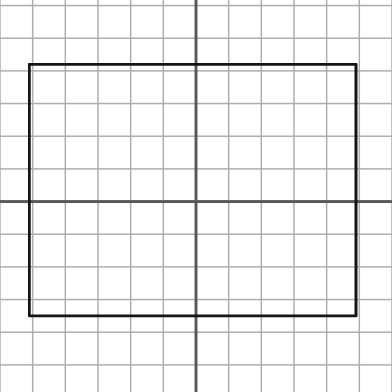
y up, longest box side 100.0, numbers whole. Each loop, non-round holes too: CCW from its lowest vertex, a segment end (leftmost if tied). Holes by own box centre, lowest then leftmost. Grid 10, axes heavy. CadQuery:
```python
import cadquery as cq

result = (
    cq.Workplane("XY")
    .moveTo(-51.0, -35.0)
    .lineTo(49.0, -35.0)
    .lineTo(49.0, 42.0)
    .lineTo(-51.0, 42.0)
    .close()
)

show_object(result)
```